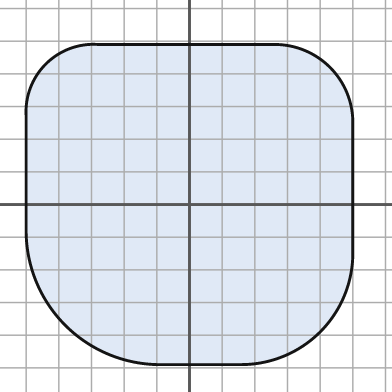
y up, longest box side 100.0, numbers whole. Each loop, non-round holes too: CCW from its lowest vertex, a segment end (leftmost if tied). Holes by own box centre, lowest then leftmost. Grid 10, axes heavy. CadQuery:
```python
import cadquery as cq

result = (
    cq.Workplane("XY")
    .moveTo(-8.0, -49.0)
    .lineTo(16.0, -49.0)
    .threePointArc((40.0, -39.0), (50.0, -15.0))
    .lineTo(50.0, 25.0)
    .threePointArc((43.0, 42.0), (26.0, 49.0))
    .lineTo(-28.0, 49.0)
    .threePointArc((-44.0, 43.0), (-50.0, 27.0))
    .lineTo(-50.0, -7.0)
    .threePointArc((-38.0, -37.0), (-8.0, -49.0))
    .close()
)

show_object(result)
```